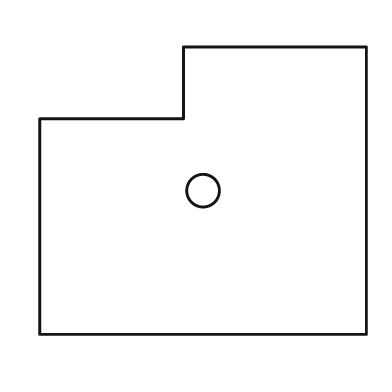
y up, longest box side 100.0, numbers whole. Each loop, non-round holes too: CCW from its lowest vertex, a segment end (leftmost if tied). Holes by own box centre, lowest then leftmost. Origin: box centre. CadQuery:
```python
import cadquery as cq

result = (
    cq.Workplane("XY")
    .moveTo(-50.0, -44.0)
    .lineTo(50.0, -44.0)
    .lineTo(50.0, 44.0)
    .lineTo(-6.0, 44.0)
    .lineTo(-6.0, 22.0)
    .lineTo(-50.0, 22.0)
    .close()
    .moveTo(0.0, 0.0)
    .circle(5.0)
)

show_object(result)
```